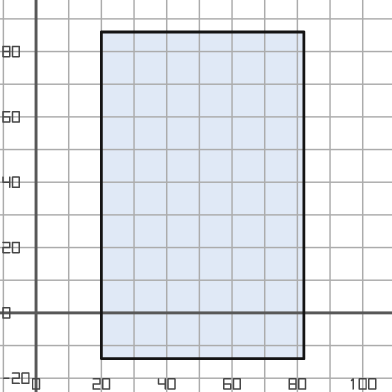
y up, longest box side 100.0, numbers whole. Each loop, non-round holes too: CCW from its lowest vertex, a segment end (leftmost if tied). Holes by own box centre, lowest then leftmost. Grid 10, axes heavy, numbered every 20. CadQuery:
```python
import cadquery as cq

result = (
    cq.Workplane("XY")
    .moveTo(20.0, -14.0)
    .lineTo(82.0, -14.0)
    .lineTo(82.0, 86.0)
    .lineTo(20.0, 86.0)
    .close()
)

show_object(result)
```